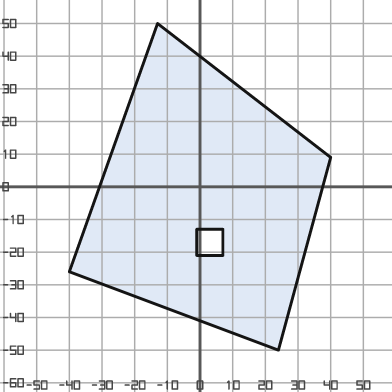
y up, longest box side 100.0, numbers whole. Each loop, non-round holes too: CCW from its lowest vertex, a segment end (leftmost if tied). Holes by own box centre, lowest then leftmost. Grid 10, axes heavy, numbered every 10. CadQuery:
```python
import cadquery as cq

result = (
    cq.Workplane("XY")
    .moveTo(24.0, -50.0)
    .lineTo(40.0, 9.0)
    .lineTo(-13.0, 50.0)
    .lineTo(-40.0, -26.0)
    .close()
    .moveTo(-1.0, -21.0)
    .lineTo(7.0, -21.0)
    .lineTo(7.0, -13.0)
    .lineTo(-1.0, -13.0)
    .close()
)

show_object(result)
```